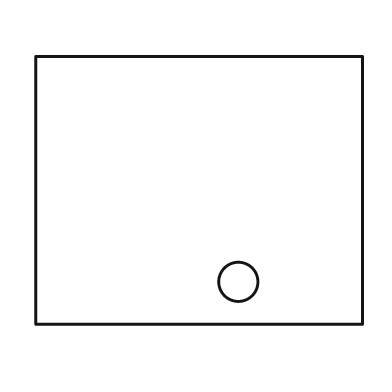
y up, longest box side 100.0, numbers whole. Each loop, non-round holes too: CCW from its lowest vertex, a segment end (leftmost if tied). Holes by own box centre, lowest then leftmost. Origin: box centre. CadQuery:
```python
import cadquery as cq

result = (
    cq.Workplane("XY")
    .moveTo(-50.0, -41.0)
    .lineTo(50.0, -41.0)
    .lineTo(50.0, 41.0)
    .lineTo(-50.0, 41.0)
    .close()
    .moveTo(12.0, -28.0)
    .circle(6.0)
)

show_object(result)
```